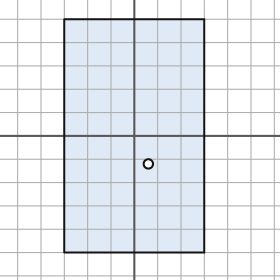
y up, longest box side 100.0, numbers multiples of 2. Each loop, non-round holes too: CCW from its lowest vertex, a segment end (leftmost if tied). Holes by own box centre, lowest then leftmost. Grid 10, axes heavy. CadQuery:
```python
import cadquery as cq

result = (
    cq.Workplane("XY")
    .moveTo(-30.0, -50.0)
    .lineTo(30.0, -50.0)
    .lineTo(30.0, 50.0)
    .lineTo(-30.0, 50.0)
    .close()
    .moveTo(6.0, -12.0)
    .circle(2.0)
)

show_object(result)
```